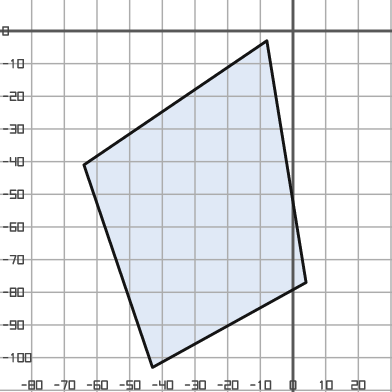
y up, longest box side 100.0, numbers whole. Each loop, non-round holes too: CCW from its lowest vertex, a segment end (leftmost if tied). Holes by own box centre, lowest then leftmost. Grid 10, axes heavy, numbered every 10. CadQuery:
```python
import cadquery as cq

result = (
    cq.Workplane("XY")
    .moveTo(-43.0, -103.0)
    .lineTo(4.0, -77.0)
    .lineTo(-8.0, -3.0)
    .lineTo(-64.0, -41.0)
    .close()
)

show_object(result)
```